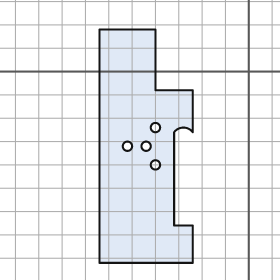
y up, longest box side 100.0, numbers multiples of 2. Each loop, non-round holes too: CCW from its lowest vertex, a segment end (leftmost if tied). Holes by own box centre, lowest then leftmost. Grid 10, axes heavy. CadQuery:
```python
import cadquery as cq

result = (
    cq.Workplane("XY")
    .moveTo(-64.0, -82.0)
    .lineTo(-24.0, -82.0)
    .lineTo(-24.0, -66.0)
    .lineTo(-32.0, -66.0)
    .lineTo(-32.0, -26.0)
    .threePointArc((-28.0, -24.0), (-24.0, -26.0))
    .lineTo(-24.0, -8.0)
    .lineTo(-40.0, -8.0)
    .lineTo(-40.0, 18.0)
    .lineTo(-64.0, 18.0)
    .close()
    .moveTo(-40.0, -40.0)
    .circle(2.0)
    .moveTo(-52.0, -32.0)
    .circle(2.0)
    .moveTo(-44.0, -32.0)
    .circle(2.0)
    .moveTo(-40.0, -24.0)
    .circle(2.0)
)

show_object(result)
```